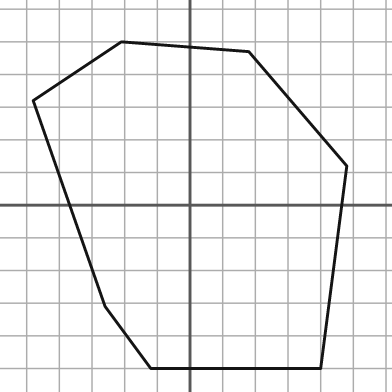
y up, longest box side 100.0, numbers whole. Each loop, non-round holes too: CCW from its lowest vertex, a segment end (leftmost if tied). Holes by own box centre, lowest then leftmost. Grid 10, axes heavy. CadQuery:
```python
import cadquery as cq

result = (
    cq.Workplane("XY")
    .moveTo(-12.0, -50.0)
    .lineTo(40.0, -50.0)
    .lineTo(48.0, 12.0)
    .lineTo(18.0, 47.0)
    .lineTo(-21.0, 50.0)
    .lineTo(-48.0, 32.0)
    .lineTo(-26.0, -31.0)
    .close()
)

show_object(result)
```